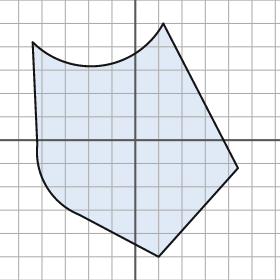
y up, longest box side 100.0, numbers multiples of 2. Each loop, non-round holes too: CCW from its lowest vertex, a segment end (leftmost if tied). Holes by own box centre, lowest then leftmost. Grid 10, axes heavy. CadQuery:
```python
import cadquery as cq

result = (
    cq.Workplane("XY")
    .moveTo(10.0, -50.0)
    .lineTo(44.0, -12.0)
    .lineTo(12.0, 50.0)
    .threePointArc((-14.0, 32.0), (-44.0, 42.0))
    .lineTo(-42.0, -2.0)
    .threePointArc((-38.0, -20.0), (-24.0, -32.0))
    .close()
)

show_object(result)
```